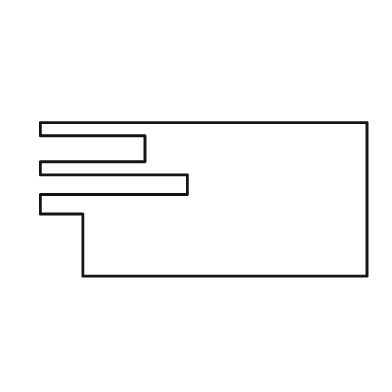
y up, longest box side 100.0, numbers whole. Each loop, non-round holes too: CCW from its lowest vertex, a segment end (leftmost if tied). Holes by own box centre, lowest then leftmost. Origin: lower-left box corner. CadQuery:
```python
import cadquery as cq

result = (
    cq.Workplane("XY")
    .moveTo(13.0, 0.0)
    .lineTo(100.0, 0.0)
    .lineTo(100.0, 47.0)
    .lineTo(0.0, 47.0)
    .lineTo(0.0, 43.0)
    .lineTo(32.0, 43.0)
    .lineTo(32.0, 35.0)
    .lineTo(0.0, 35.0)
    .lineTo(0.0, 31.0)
    .lineTo(45.0, 31.0)
    .lineTo(45.0, 25.0)
    .lineTo(0.0, 25.0)
    .lineTo(0.0, 19.0)
    .lineTo(13.0, 19.0)
    .close()
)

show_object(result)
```